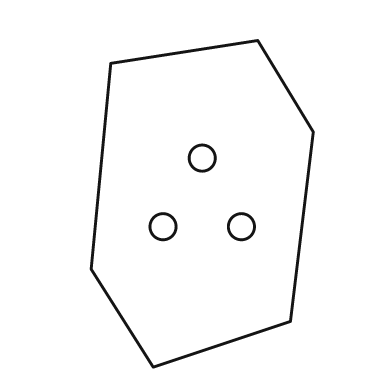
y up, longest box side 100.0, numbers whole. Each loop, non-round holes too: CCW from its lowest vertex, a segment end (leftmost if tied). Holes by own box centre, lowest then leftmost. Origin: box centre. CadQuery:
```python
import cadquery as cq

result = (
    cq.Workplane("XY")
    .moveTo(-15.0, -50.0)
    .lineTo(27.0, -36.0)
    .lineTo(34.0, 22.0)
    .lineTo(17.0, 50.0)
    .lineTo(-28.0, 43.0)
    .lineTo(-34.0, -20.0)
    .close()
    .moveTo(-12.0, -7.0)
    .circle(4.0)
    .moveTo(12.0, -7.0)
    .circle(4.0)
    .moveTo(0.0, 14.0)
    .circle(4.0)
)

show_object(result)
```